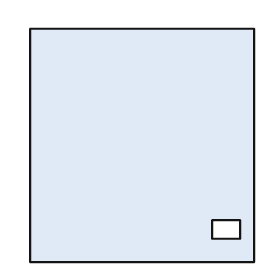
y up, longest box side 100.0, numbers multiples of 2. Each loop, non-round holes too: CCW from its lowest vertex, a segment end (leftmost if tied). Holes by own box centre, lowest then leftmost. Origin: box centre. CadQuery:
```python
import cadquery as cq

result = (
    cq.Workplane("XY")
    .moveTo(-48.0, -50.0)
    .lineTo(48.0, -50.0)
    .lineTo(48.0, 50.0)
    .lineTo(-48.0, 50.0)
    .close()
    .moveTo(30.0, -40.0)
    .lineTo(42.0, -40.0)
    .lineTo(42.0, -32.0)
    .lineTo(30.0, -32.0)
    .close()
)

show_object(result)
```